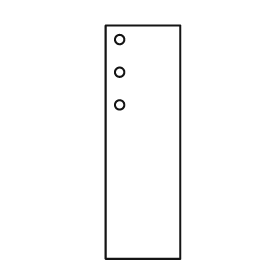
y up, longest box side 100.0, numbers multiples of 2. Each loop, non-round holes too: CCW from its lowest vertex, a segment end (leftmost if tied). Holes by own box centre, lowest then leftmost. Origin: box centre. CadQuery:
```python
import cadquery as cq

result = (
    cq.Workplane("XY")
    .moveTo(-16.0, -50.0)
    .lineTo(16.0, -50.0)
    .lineTo(16.0, 50.0)
    .lineTo(-16.0, 50.0)
    .close()
    .moveTo(-10.0, 16.0)
    .circle(2.0)
    .moveTo(-10.0, 30.0)
    .circle(2.0)
    .moveTo(-10.0, 44.0)
    .circle(2.0)
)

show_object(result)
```